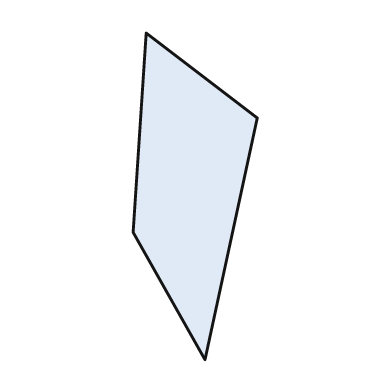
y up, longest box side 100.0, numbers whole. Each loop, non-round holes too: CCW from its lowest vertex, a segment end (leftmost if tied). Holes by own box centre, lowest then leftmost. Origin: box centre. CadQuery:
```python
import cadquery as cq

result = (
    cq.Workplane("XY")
    .moveTo(3.0, -50.0)
    .lineTo(19.0, 24.0)
    .lineTo(-15.0, 50.0)
    .lineTo(-19.0, -11.0)
    .close()
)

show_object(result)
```